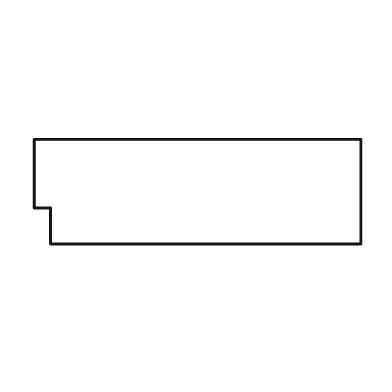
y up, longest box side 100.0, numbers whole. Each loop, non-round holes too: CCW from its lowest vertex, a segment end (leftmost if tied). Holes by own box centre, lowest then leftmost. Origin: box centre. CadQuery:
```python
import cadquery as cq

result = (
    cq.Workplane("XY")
    .moveTo(-45.0, -16.0)
    .lineTo(50.0, -16.0)
    .lineTo(50.0, 16.0)
    .lineTo(-50.0, 16.0)
    .lineTo(-50.0, -5.0)
    .lineTo(-45.0, -5.0)
    .close()
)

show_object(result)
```